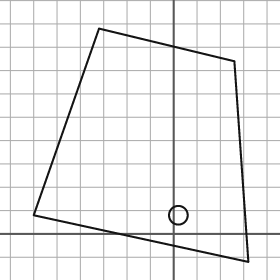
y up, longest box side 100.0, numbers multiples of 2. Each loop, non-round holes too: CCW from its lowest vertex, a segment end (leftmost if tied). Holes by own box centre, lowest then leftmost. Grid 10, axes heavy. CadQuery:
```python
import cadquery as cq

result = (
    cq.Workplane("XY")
    .moveTo(32.0, -12.0)
    .lineTo(26.0, 74.0)
    .lineTo(-32.0, 88.0)
    .lineTo(-60.0, 8.0)
    .close()
    .moveTo(2.0, 8.0)
    .circle(4.0)
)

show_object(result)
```